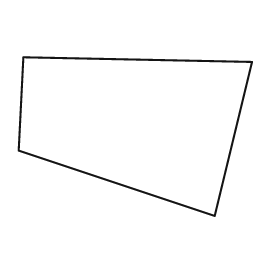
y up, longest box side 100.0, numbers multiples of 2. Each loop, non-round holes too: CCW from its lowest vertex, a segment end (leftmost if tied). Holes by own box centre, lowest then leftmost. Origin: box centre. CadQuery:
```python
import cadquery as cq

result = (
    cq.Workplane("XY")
    .moveTo(34.0, -34.0)
    .lineTo(50.0, 32.0)
    .lineTo(-48.0, 34.0)
    .lineTo(-50.0, -6.0)
    .close()
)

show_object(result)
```